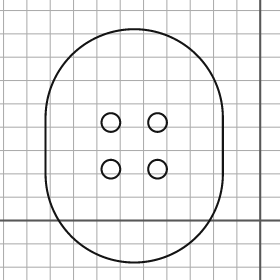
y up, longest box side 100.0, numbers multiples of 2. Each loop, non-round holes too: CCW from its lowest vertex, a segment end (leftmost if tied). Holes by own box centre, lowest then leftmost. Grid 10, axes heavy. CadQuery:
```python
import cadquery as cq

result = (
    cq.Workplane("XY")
    .moveTo(-92.0, 20.0)
    .threePointArc((-54.0, -18.0), (-16.0, 20.0))
    .lineTo(-16.0, 44.0)
    .threePointArc((-54.0, 82.0), (-92.0, 44.0))
    .close()
    .moveTo(-64.0, 22.0)
    .circle(4.0)
    .moveTo(-44.0, 22.0)
    .circle(4.0)
    .moveTo(-64.0, 42.0)
    .circle(4.0)
    .moveTo(-44.0, 42.0)
    .circle(4.0)
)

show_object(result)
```